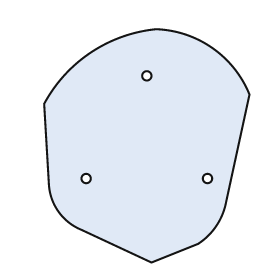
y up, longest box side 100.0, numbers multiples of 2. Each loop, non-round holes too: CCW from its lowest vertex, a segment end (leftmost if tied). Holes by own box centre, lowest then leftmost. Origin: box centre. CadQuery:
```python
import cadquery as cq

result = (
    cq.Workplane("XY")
    .moveTo(2.0, -50.0)
    .lineTo(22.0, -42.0)
    .threePointArc((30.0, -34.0), (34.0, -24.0))
    .lineTo(44.0, 22.0)
    .threePointArc((28.0, 42.0), (4.0, 50.0))
    .threePointArc((-24.0, 40.0), (-44.0, 18.0))
    .lineTo(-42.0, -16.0)
    .threePointArc((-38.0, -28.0), (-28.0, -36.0))
    .close()
    .moveTo(-26.0, -14.0)
    .circle(2.0)
    .moveTo(26.0, -14.0)
    .circle(2.0)
    .moveTo(0.0, 30.0)
    .circle(2.0)
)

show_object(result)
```